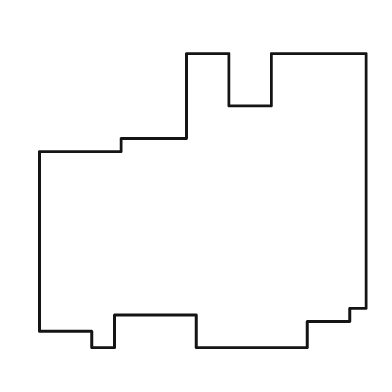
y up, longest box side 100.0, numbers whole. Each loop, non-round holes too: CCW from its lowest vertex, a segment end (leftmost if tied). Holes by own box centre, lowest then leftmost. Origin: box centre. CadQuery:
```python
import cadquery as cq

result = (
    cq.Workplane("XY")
    .moveTo(-34.0, -45.0)
    .lineTo(-27.0, -45.0)
    .lineTo(-27.0, -35.0)
    .lineTo(-2.0, -35.0)
    .lineTo(-2.0, -45.0)
    .lineTo(32.0, -45.0)
    .lineTo(32.0, -37.0)
    .lineTo(45.0, -37.0)
    .lineTo(45.0, -33.0)
    .lineTo(50.0, -33.0)
    .lineTo(50.0, 45.0)
    .lineTo(21.0, 45.0)
    .lineTo(21.0, 29.0)
    .lineTo(8.0, 29.0)
    .lineTo(8.0, 45.0)
    .lineTo(-5.0, 45.0)
    .lineTo(-5.0, 19.0)
    .lineTo(-25.0, 19.0)
    .lineTo(-25.0, 15.0)
    .lineTo(-50.0, 15.0)
    .lineTo(-50.0, -40.0)
    .lineTo(-34.0, -40.0)
    .close()
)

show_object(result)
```